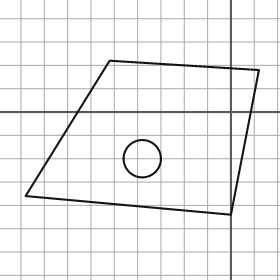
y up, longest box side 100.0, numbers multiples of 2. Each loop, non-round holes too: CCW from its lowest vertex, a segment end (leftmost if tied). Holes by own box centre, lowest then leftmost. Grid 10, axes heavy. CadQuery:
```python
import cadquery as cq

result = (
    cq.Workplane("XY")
    .moveTo(0.0, -44.0)
    .lineTo(12.0, 18.0)
    .lineTo(-52.0, 22.0)
    .lineTo(-88.0, -36.0)
    .close()
    .moveTo(-38.0, -20.0)
    .circle(8.0)
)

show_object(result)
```